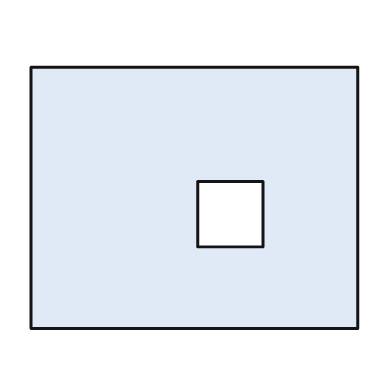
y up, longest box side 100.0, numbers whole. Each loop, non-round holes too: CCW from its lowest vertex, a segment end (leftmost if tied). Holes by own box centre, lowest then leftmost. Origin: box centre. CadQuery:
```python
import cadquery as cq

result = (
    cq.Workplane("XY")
    .moveTo(-50.0, -40.0)
    .lineTo(50.0, -40.0)
    .lineTo(50.0, 40.0)
    .lineTo(-50.0, 40.0)
    .close()
    .moveTo(1.0, -15.0)
    .lineTo(21.0, -15.0)
    .lineTo(21.0, 5.0)
    .lineTo(1.0, 5.0)
    .close()
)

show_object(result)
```